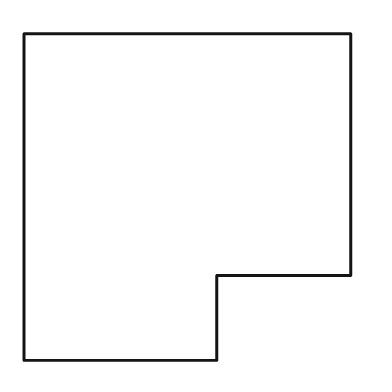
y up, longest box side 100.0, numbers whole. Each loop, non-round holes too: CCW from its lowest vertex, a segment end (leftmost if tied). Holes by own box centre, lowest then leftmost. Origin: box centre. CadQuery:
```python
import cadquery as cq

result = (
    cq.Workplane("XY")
    .moveTo(-50.0, -50.0)
    .lineTo(9.0, -50.0)
    .lineTo(9.0, -24.0)
    .lineTo(50.0, -24.0)
    .lineTo(50.0, 50.0)
    .lineTo(-50.0, 50.0)
    .close()
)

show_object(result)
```